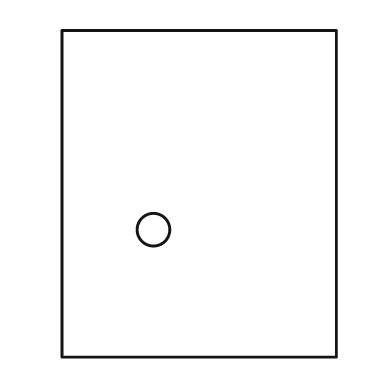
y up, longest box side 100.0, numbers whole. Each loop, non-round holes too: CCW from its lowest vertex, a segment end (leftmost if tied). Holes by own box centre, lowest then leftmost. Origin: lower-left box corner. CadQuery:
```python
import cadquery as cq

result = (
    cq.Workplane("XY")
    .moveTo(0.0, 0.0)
    .lineTo(84.0, 0.0)
    .lineTo(84.0, 100.0)
    .lineTo(0.0, 100.0)
    .close()
    .moveTo(28.0, 39.0)
    .circle(5.0)
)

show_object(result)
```